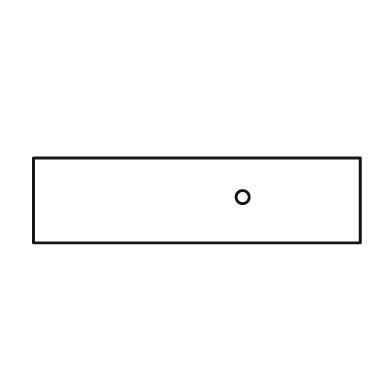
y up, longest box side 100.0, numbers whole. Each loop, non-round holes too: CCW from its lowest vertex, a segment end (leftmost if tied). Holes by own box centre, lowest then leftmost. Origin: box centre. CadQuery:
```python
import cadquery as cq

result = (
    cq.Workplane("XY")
    .moveTo(-50.0, -13.0)
    .lineTo(50.0, -13.0)
    .lineTo(50.0, 13.0)
    .lineTo(-50.0, 13.0)
    .close()
    .moveTo(14.0, 1.0)
    .circle(2.0)
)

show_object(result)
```